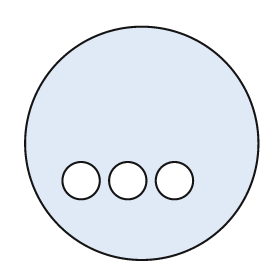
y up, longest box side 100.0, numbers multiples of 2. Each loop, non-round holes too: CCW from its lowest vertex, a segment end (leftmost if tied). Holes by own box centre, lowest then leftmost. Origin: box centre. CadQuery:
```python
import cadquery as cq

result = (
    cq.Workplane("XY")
    .moveTo(0.0, 0.0)
    .circle(50.0)
    .moveTo(-26.0, -16.0)
    .circle(8.0)
    .moveTo(-6.0, -16.0)
    .circle(8.0)
    .moveTo(14.0, -16.0)
    .circle(8.0)
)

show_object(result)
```